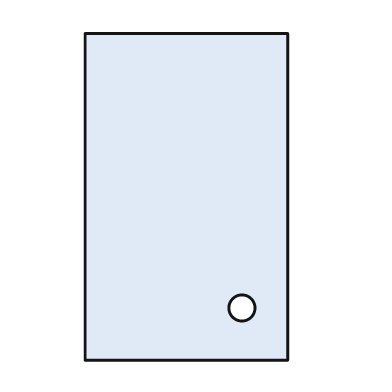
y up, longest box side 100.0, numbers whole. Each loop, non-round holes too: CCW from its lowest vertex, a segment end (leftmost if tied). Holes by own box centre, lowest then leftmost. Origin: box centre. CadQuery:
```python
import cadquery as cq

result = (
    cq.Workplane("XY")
    .moveTo(-31.0, -50.0)
    .lineTo(31.0, -50.0)
    .lineTo(31.0, 50.0)
    .lineTo(-31.0, 50.0)
    .close()
    .moveTo(17.0, -34.0)
    .circle(4.0)
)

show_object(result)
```